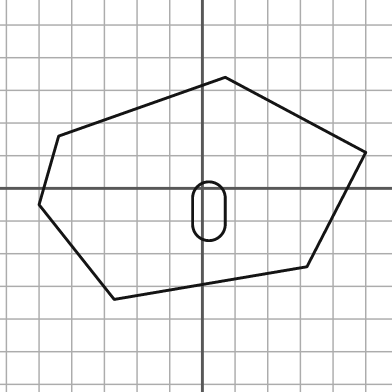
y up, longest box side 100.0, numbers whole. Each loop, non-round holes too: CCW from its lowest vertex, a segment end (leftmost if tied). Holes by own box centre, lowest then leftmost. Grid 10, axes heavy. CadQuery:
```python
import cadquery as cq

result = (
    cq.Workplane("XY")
    .moveTo(-27.0, -34.0)
    .lineTo(32.0, -24.0)
    .lineTo(50.0, 11.0)
    .lineTo(7.0, 34.0)
    .lineTo(-44.0, 16.0)
    .lineTo(-50.0, -5.0)
    .close()
    .moveTo(-3.0, -11.0)
    .threePointArc((2.0, -16.0), (7.0, -11.0))
    .lineTo(7.0, -3.0)
    .threePointArc((2.0, 2.0), (-3.0, -3.0))
    .close()
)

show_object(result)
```